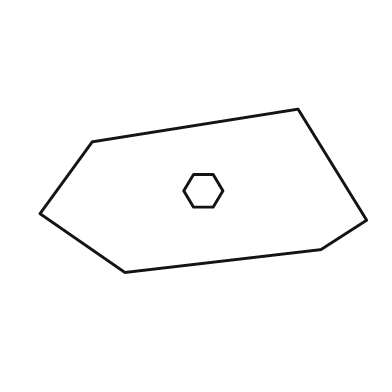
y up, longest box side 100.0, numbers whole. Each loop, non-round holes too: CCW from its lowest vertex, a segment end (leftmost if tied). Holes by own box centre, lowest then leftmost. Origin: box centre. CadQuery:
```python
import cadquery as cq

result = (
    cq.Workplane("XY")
    .moveTo(-24.0, -25.0)
    .lineTo(36.0, -18.0)
    .lineTo(50.0, -9.0)
    .lineTo(29.0, 25.0)
    .lineTo(-34.0, 15.0)
    .lineTo(-50.0, -7.0)
    .close()
    .moveTo(-3.0, -5.0)
    .lineTo(3.0, -5.0)
    .lineTo(6.0, 0.0)
    .lineTo(3.0, 5.0)
    .lineTo(-3.0, 5.0)
    .lineTo(-6.0, 0.0)
    .close()
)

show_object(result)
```